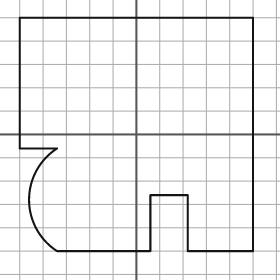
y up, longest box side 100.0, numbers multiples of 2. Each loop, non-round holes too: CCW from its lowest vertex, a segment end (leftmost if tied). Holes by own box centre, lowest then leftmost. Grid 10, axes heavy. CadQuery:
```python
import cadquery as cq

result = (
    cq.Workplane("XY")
    .moveTo(-34.0, -50.0)
    .lineTo(6.0, -50.0)
    .lineTo(6.0, -26.0)
    .lineTo(22.0, -26.0)
    .lineTo(22.0, -50.0)
    .lineTo(50.0, -50.0)
    .lineTo(50.0, 50.0)
    .lineTo(-50.0, 50.0)
    .lineTo(-50.0, -6.0)
    .lineTo(-34.0, -6.0)
    .threePointArc((-46.0, -28.0), (-34.0, -50.0))
    .close()
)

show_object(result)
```